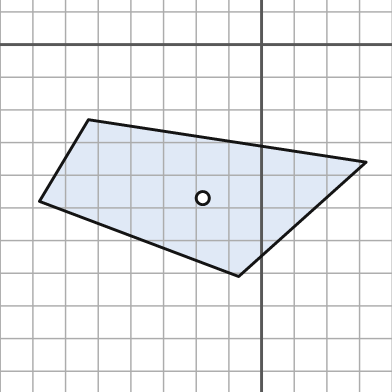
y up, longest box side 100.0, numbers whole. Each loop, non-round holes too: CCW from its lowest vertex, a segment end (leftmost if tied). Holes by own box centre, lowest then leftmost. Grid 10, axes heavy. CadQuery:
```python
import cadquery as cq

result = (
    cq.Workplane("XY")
    .moveTo(-7.0, -71.0)
    .lineTo(32.0, -36.0)
    .lineTo(-53.0, -23.0)
    .lineTo(-68.0, -48.0)
    .close()
    .moveTo(-18.0, -47.0)
    .circle(2.0)
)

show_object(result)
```